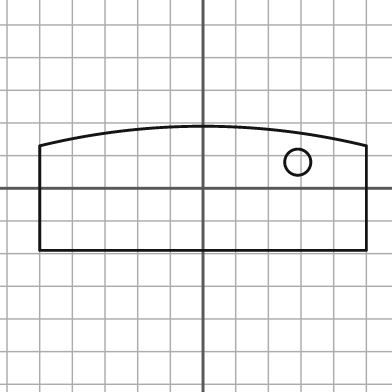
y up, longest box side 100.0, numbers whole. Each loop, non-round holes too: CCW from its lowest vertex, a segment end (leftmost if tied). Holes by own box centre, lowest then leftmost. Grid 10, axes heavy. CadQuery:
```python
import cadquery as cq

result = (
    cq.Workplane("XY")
    .moveTo(-50.0, -19.0)
    .lineTo(50.0, -19.0)
    .lineTo(50.0, 13.0)
    .threePointArc((0.0, 19.0), (-50.0, 13.0))
    .close()
    .moveTo(29.0, 8.0)
    .circle(4.0)
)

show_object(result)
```